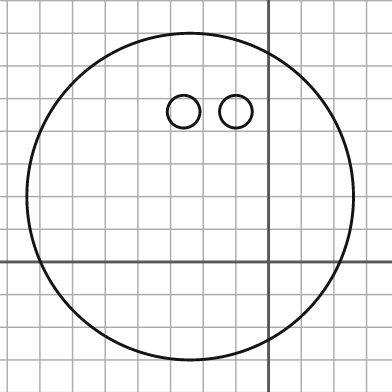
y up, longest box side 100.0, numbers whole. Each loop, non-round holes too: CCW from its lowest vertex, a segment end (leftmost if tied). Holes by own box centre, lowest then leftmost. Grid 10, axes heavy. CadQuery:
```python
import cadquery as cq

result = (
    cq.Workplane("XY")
    .moveTo(-24.0, 20.0)
    .circle(50.0)
    .moveTo(-26.0, 46.0)
    .circle(5.0)
    .moveTo(-10.0, 46.0)
    .circle(5.0)
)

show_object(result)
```